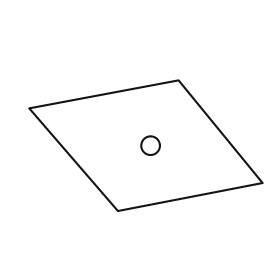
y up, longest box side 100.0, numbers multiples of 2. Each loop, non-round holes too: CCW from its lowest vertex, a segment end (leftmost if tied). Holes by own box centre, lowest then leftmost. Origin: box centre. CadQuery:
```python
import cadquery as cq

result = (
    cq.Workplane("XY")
    .moveTo(-12.0, -28.0)
    .lineTo(50.0, -16.0)
    .lineTo(14.0, 28.0)
    .lineTo(-50.0, 16.0)
    .close()
    .moveTo(2.0, 0.0)
    .circle(4.0)
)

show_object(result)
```